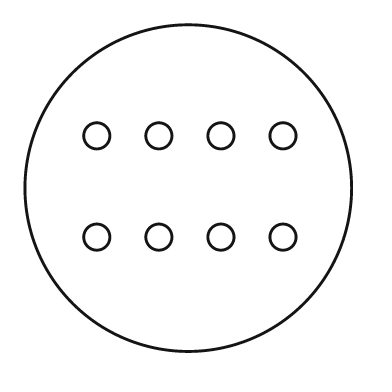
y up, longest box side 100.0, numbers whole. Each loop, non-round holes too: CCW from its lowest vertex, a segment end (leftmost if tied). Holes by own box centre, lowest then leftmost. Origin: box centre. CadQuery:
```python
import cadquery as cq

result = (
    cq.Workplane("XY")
    .moveTo(0.0, 0.0)
    .circle(50.0)
    .moveTo(-28.0, -15.0)
    .circle(4.0)
    .moveTo(-9.0, -15.0)
    .circle(4.0)
    .moveTo(10.0, -15.0)
    .circle(4.0)
    .moveTo(29.0, -15.0)
    .circle(4.0)
    .moveTo(-28.0, 16.0)
    .circle(4.0)
    .moveTo(-9.0, 16.0)
    .circle(4.0)
    .moveTo(10.0, 16.0)
    .circle(4.0)
    .moveTo(29.0, 16.0)
    .circle(4.0)
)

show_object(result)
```